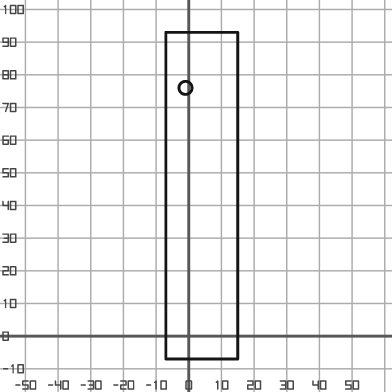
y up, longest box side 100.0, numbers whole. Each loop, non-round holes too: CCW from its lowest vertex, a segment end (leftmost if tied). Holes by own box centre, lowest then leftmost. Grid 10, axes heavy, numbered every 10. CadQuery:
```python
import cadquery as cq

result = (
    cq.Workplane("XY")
    .moveTo(-7.0, -7.0)
    .lineTo(15.0, -7.0)
    .lineTo(15.0, 93.0)
    .lineTo(-7.0, 93.0)
    .close()
    .moveTo(-1.0, 76.0)
    .circle(2.0)
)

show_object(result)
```